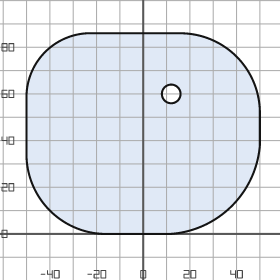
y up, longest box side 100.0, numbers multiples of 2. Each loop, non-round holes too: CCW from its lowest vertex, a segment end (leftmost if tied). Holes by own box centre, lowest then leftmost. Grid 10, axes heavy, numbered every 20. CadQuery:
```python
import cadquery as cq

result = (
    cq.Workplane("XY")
    .moveTo(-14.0, 0.0)
    .lineTo(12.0, 0.0)
    .threePointArc((38.0, 12.0), (50.0, 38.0))
    .lineTo(50.0, 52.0)
    .threePointArc((40.0, 76.0), (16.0, 86.0))
    .lineTo(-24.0, 86.0)
    .threePointArc((-42.0, 78.0), (-50.0, 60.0))
    .lineTo(-50.0, 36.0)
    .threePointArc((-40.0, 10.0), (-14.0, 0.0))
    .close()
    .moveTo(12.0, 60.0)
    .circle(4.0)
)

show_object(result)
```